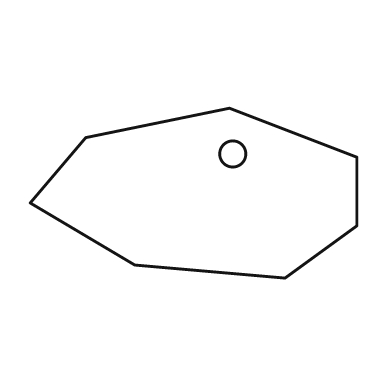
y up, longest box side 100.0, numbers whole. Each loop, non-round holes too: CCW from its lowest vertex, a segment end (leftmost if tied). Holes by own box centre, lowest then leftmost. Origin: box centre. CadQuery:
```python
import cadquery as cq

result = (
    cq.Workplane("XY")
    .moveTo(28.0, -26.0)
    .lineTo(50.0, -10.0)
    .lineTo(50.0, 11.0)
    .lineTo(11.0, 26.0)
    .lineTo(-33.0, 17.0)
    .lineTo(-50.0, -3.0)
    .lineTo(-18.0, -22.0)
    .close()
    .moveTo(12.0, 12.0)
    .circle(4.0)
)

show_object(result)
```